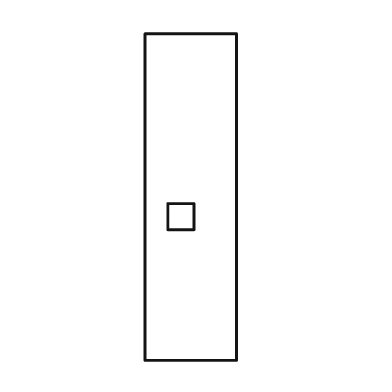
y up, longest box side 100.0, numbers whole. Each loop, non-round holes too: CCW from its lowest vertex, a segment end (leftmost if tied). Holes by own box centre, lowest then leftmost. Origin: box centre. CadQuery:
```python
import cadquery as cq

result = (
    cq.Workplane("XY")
    .moveTo(-14.0, -50.0)
    .lineTo(14.0, -50.0)
    .lineTo(14.0, 50.0)
    .lineTo(-14.0, 50.0)
    .close()
    .moveTo(-7.0, -10.0)
    .lineTo(1.0, -10.0)
    .lineTo(1.0, -2.0)
    .lineTo(-7.0, -2.0)
    .close()
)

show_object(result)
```